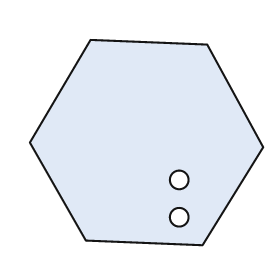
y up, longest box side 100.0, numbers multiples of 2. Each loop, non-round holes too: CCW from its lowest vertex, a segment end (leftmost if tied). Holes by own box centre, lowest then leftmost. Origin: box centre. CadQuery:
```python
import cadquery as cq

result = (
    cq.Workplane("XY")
    .moveTo(24.0, -44.0)
    .lineTo(50.0, -2.0)
    .lineTo(26.0, 42.0)
    .lineTo(-24.0, 44.0)
    .lineTo(-50.0, 0.0)
    .lineTo(-26.0, -42.0)
    .close()
    .moveTo(14.0, -32.0)
    .circle(4.0)
    .moveTo(14.0, -16.0)
    .circle(4.0)
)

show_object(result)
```